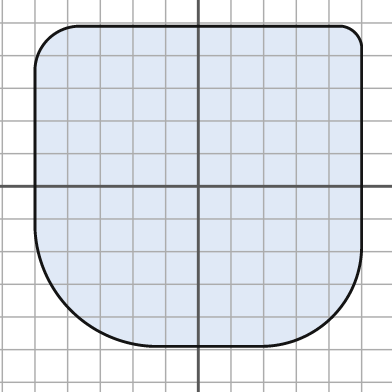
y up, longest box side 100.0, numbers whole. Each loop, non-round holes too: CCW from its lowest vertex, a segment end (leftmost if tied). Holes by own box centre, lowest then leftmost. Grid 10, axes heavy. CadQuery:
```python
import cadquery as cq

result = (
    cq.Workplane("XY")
    .moveTo(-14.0, -49.0)
    .lineTo(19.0, -49.0)
    .threePointArc((41.0, -40.0), (50.0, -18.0))
    .lineTo(50.0, 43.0)
    .threePointArc((48.0, 47.0), (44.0, 49.0))
    .lineTo(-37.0, 49.0)
    .threePointArc((-46.0, 45.0), (-50.0, 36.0))
    .lineTo(-50.0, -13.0)
    .threePointArc((-39.0, -38.0), (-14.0, -49.0))
    .close()
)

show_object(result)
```